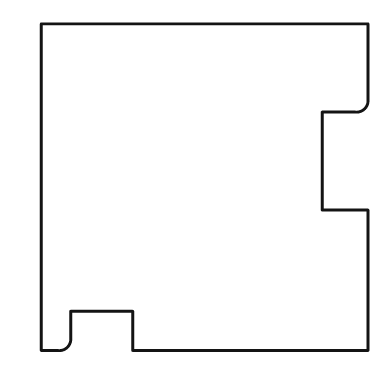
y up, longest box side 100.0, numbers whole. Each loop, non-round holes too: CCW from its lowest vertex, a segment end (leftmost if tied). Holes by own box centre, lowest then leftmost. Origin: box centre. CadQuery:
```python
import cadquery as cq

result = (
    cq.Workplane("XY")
    .moveTo(-50.0, -50.0)
    .lineTo(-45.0, -50.0)
    .threePointArc((-42.0, -49.0), (-41.0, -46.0))
    .lineTo(-41.0, -38.0)
    .lineTo(-22.0, -38.0)
    .lineTo(-22.0, -50.0)
    .lineTo(50.0, -50.0)
    .lineTo(50.0, -7.0)
    .lineTo(36.0, -7.0)
    .lineTo(36.0, 23.0)
    .lineTo(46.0, 23.0)
    .threePointArc((49.0, 24.0), (50.0, 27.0))
    .lineTo(50.0, 50.0)
    .lineTo(-50.0, 50.0)
    .close()
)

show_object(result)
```